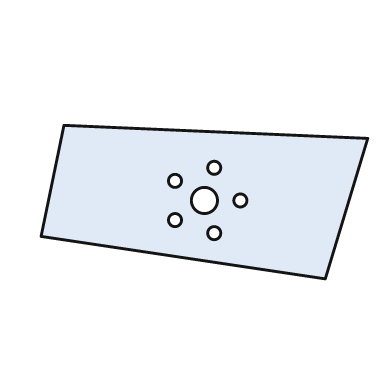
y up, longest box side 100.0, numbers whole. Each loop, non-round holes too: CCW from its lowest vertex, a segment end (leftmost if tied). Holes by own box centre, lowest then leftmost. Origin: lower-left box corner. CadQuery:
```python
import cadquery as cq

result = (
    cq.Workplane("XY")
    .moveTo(87.0, 0.0)
    .lineTo(100.0, 43.0)
    .lineTo(7.0, 47.0)
    .lineTo(0.0, 13.0)
    .close()
    .moveTo(53.0, 14.0)
    .circle(2.0)
    .moveTo(41.0, 18.0)
    .circle(2.0)
    .moveTo(50.0, 24.0)
    .circle(4.0)
    .moveTo(61.0, 24.0)
    .circle(2.0)
    .moveTo(41.0, 30.0)
    .circle(2.0)
    .moveTo(53.0, 34.0)
    .circle(2.0)
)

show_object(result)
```